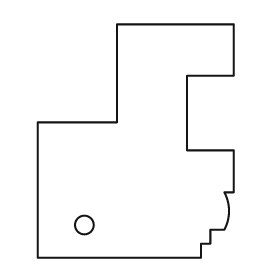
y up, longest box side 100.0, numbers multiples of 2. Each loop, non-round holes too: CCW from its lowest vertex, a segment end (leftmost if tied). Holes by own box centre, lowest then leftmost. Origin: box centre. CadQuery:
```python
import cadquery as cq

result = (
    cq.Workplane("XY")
    .moveTo(-42.0, -50.0)
    .lineTo(28.0, -50.0)
    .lineTo(28.0, -44.0)
    .lineTo(32.0, -44.0)
    .lineTo(32.0, -38.0)
    .lineTo(38.0, -38.0)
    .threePointArc((40.0, -30.0), (38.0, -22.0))
    .lineTo(42.0, -22.0)
    .lineTo(42.0, -4.0)
    .lineTo(22.0, -4.0)
    .lineTo(22.0, 28.0)
    .lineTo(42.0, 28.0)
    .lineTo(42.0, 50.0)
    .lineTo(-8.0, 50.0)
    .lineTo(-8.0, 8.0)
    .lineTo(-42.0, 8.0)
    .close()
    .moveTo(-22.0, -36.0)
    .circle(4.0)
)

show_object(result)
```